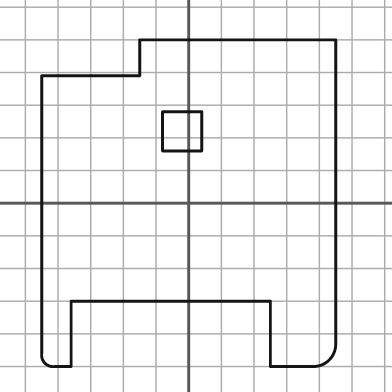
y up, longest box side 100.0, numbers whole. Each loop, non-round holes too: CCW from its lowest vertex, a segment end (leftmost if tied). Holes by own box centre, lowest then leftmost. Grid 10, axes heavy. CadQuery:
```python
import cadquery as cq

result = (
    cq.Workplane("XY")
    .moveTo(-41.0, -50.0)
    .lineTo(-36.0, -50.0)
    .lineTo(-36.0, -30.0)
    .lineTo(25.0, -30.0)
    .lineTo(25.0, -50.0)
    .lineTo(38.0, -50.0)
    .threePointArc((43.0, -48.0), (45.0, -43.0))
    .lineTo(45.0, 50.0)
    .lineTo(-15.0, 50.0)
    .lineTo(-15.0, 39.0)
    .lineTo(-45.0, 39.0)
    .lineTo(-45.0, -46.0)
    .threePointArc((-44.0, -49.0), (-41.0, -50.0))
    .close()
    .moveTo(-8.0, 16.0)
    .lineTo(4.0, 16.0)
    .lineTo(4.0, 28.0)
    .lineTo(-8.0, 28.0)
    .close()
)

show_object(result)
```